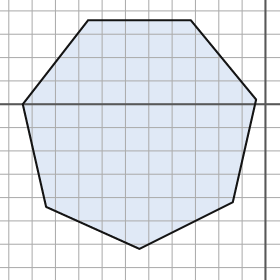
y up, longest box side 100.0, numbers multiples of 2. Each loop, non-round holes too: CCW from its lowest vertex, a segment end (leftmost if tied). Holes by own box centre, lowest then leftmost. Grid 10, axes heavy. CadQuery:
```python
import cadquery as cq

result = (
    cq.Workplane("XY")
    .moveTo(-54.0, -62.0)
    .lineTo(-14.0, -42.0)
    .lineTo(-4.0, 2.0)
    .lineTo(-32.0, 36.0)
    .lineTo(-76.0, 36.0)
    .lineTo(-104.0, 0.0)
    .lineTo(-94.0, -44.0)
    .close()
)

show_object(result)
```